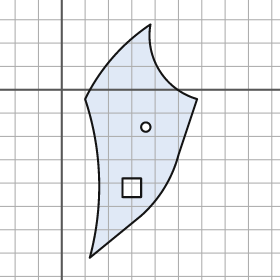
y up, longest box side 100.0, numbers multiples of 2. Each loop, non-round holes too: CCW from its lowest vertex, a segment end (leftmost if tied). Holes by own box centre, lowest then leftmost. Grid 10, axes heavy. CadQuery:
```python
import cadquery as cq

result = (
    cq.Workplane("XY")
    .moveTo(12.0, -72.0)
    .lineTo(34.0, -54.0)
    .threePointArc((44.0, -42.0), (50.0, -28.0))
    .lineTo(58.0, -4.0)
    .threePointArc((42.0, 8.0), (38.0, 28.0))
    .threePointArc((22.0, 14.0), (10.0, -4.0))
    .threePointArc((16.0, -38.0), (12.0, -72.0))
    .close()
    .moveTo(26.0, -46.0)
    .lineTo(34.0, -46.0)
    .lineTo(34.0, -38.0)
    .lineTo(26.0, -38.0)
    .close()
    .moveTo(36.0, -16.0)
    .circle(2.0)
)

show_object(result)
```